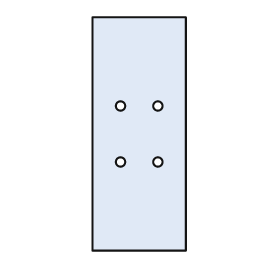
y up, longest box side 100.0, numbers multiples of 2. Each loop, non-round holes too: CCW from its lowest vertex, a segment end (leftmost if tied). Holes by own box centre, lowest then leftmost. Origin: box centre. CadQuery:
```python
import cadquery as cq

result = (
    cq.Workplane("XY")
    .moveTo(-20.0, -50.0)
    .lineTo(20.0, -50.0)
    .lineTo(20.0, 50.0)
    .lineTo(-20.0, 50.0)
    .close()
    .moveTo(-8.0, -12.0)
    .circle(2.0)
    .moveTo(8.0, -12.0)
    .circle(2.0)
    .moveTo(-8.0, 12.0)
    .circle(2.0)
    .moveTo(8.0, 12.0)
    .circle(2.0)
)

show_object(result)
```